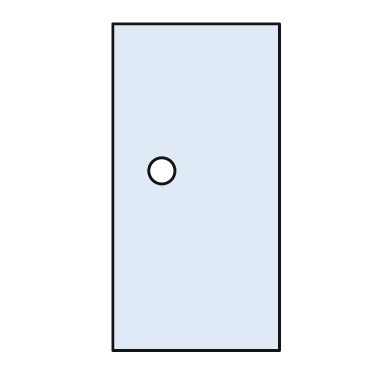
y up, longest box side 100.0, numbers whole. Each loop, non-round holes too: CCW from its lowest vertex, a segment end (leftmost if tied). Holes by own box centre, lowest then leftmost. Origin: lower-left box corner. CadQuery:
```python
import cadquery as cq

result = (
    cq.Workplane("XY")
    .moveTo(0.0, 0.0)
    .lineTo(51.0, 0.0)
    .lineTo(51.0, 100.0)
    .lineTo(0.0, 100.0)
    .close()
    .moveTo(15.0, 55.0)
    .circle(4.0)
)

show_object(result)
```